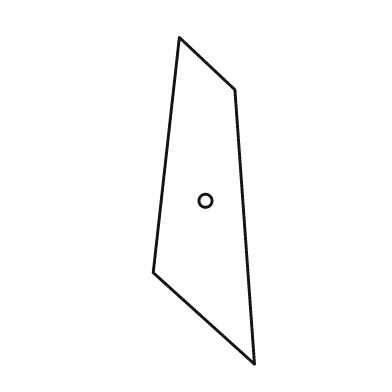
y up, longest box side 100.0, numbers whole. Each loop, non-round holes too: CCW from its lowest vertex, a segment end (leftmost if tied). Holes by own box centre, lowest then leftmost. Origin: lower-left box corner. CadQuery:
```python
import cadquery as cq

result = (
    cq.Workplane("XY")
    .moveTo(31.0, 0.0)
    .lineTo(25.0, 84.0)
    .lineTo(8.0, 100.0)
    .lineTo(0.0, 28.0)
    .close()
    .moveTo(16.0, 50.0)
    .circle(2.0)
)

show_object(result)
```